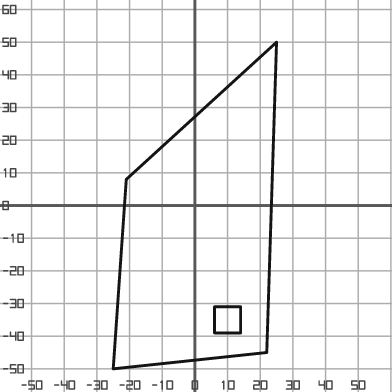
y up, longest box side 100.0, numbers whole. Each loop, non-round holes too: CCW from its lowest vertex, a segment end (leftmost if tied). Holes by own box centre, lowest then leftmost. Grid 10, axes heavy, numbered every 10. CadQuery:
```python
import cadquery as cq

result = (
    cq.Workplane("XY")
    .moveTo(-25.0, -50.0)
    .lineTo(22.0, -45.0)
    .lineTo(25.0, 50.0)
    .lineTo(-21.0, 8.0)
    .close()
    .moveTo(6.0, -39.0)
    .lineTo(14.0, -39.0)
    .lineTo(14.0, -31.0)
    .lineTo(6.0, -31.0)
    .close()
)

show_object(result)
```